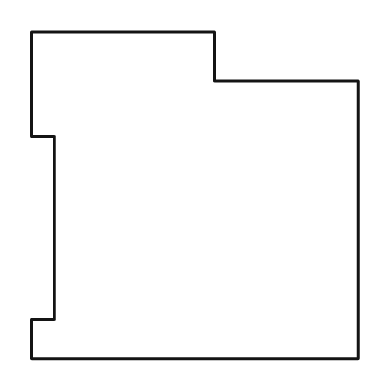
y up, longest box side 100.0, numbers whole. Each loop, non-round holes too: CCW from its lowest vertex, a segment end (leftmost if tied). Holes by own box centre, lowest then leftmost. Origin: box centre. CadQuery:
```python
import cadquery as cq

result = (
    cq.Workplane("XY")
    .moveTo(-50.0, -50.0)
    .lineTo(50.0, -50.0)
    .lineTo(50.0, 35.0)
    .lineTo(6.0, 35.0)
    .lineTo(6.0, 50.0)
    .lineTo(-50.0, 50.0)
    .lineTo(-50.0, 18.0)
    .lineTo(-43.0, 18.0)
    .lineTo(-43.0, -38.0)
    .lineTo(-50.0, -38.0)
    .close()
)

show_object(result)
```